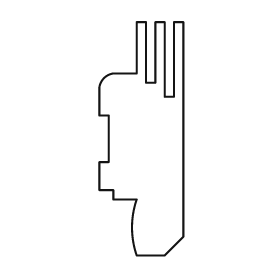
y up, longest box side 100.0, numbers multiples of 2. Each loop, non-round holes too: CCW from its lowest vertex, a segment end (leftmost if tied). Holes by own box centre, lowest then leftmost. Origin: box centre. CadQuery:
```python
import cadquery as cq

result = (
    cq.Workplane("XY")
    .moveTo(-2.0, -50.0)
    .lineTo(10.0, -50.0)
    .lineTo(18.0, -42.0)
    .lineTo(18.0, 50.0)
    .lineTo(14.0, 50.0)
    .lineTo(14.0, 18.0)
    .lineTo(10.0, 18.0)
    .lineTo(10.0, 50.0)
    .lineTo(6.0, 50.0)
    .lineTo(6.0, 24.0)
    .lineTo(2.0, 24.0)
    .lineTo(2.0, 50.0)
    .lineTo(-2.0, 50.0)
    .lineTo(-2.0, 28.0)
    .lineTo(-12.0, 28.0)
    .threePointArc((-16.0, 26.0), (-18.0, 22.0))
    .lineTo(-18.0, 10.0)
    .lineTo(-14.0, 10.0)
    .lineTo(-14.0, -10.0)
    .lineTo(-18.0, -10.0)
    .lineTo(-18.0, -22.0)
    .lineTo(-12.0, -22.0)
    .lineTo(-12.0, -26.0)
    .lineTo(-2.0, -26.0)
    .threePointArc((-4.0, -38.0), (-2.0, -50.0))
    .close()
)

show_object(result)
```